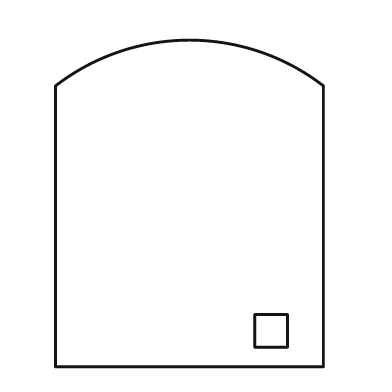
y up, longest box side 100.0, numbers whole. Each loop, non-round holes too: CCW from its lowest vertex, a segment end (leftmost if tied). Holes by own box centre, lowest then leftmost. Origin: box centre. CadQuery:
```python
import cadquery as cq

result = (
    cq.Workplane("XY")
    .moveTo(-41.0, -50.0)
    .lineTo(41.0, -50.0)
    .lineTo(41.0, 36.0)
    .threePointArc((0.0, 50.0), (-41.0, 36.0))
    .close()
    .moveTo(20.0, -44.0)
    .lineTo(30.0, -44.0)
    .lineTo(30.0, -34.0)
    .lineTo(20.0, -34.0)
    .close()
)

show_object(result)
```